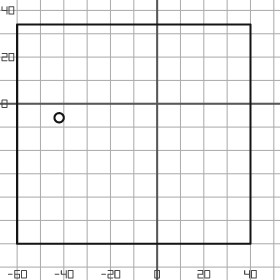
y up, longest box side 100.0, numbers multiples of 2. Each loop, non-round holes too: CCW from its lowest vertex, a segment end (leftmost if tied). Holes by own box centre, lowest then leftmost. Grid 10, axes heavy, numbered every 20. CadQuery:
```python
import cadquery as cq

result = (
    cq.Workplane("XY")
    .moveTo(-60.0, -60.0)
    .lineTo(40.0, -60.0)
    .lineTo(40.0, 34.0)
    .lineTo(-60.0, 34.0)
    .close()
    .moveTo(-42.0, -6.0)
    .circle(2.0)
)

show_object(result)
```